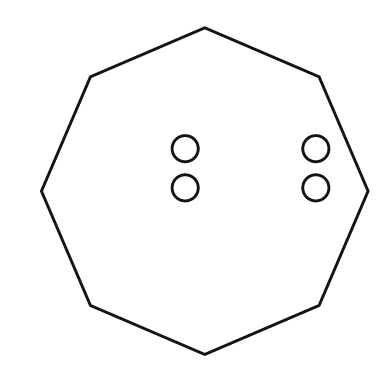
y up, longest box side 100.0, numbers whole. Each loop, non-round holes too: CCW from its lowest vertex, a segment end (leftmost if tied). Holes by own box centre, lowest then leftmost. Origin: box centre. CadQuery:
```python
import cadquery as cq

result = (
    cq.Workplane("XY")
    .moveTo(0.0, -50.0)
    .lineTo(35.0, -35.0)
    .lineTo(50.0, 0.0)
    .lineTo(35.0, 35.0)
    .lineTo(0.0, 50.0)
    .lineTo(-35.0, 35.0)
    .lineTo(-50.0, 0.0)
    .lineTo(-35.0, -35.0)
    .close()
    .moveTo(-6.0, 1.0)
    .circle(4.0)
    .moveTo(34.0, 1.0)
    .circle(4.0)
    .moveTo(-6.0, 13.0)
    .circle(4.0)
    .moveTo(34.0, 13.0)
    .circle(4.0)
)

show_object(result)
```